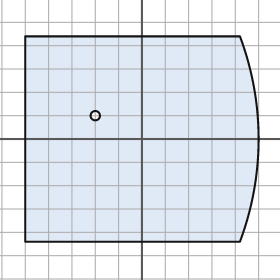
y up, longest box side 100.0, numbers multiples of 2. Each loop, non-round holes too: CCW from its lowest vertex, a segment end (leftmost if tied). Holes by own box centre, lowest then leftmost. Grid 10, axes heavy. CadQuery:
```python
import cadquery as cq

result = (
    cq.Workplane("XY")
    .moveTo(-50.0, -44.0)
    .lineTo(42.0, -44.0)
    .threePointArc((50.0, 0.0), (42.0, 44.0))
    .lineTo(-50.0, 44.0)
    .close()
    .moveTo(-20.0, 10.0)
    .circle(2.0)
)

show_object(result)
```